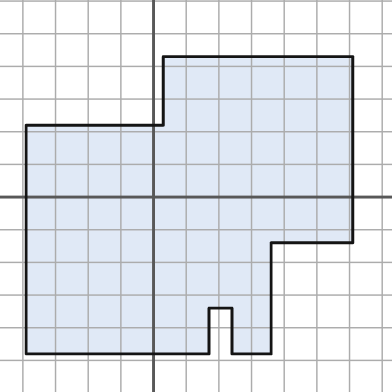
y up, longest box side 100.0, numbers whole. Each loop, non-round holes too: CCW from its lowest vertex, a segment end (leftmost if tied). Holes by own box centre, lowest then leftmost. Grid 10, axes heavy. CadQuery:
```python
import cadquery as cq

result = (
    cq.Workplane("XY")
    .moveTo(-39.0, -48.0)
    .lineTo(17.0, -48.0)
    .lineTo(17.0, -34.0)
    .lineTo(24.0, -34.0)
    .lineTo(24.0, -48.0)
    .lineTo(36.0, -48.0)
    .lineTo(36.0, -14.0)
    .lineTo(61.0, -14.0)
    .lineTo(61.0, 43.0)
    .lineTo(3.0, 43.0)
    .lineTo(3.0, 22.0)
    .lineTo(-39.0, 22.0)
    .close()
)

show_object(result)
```